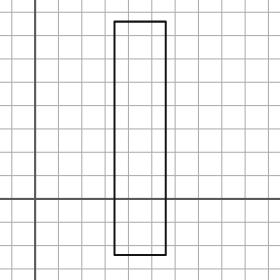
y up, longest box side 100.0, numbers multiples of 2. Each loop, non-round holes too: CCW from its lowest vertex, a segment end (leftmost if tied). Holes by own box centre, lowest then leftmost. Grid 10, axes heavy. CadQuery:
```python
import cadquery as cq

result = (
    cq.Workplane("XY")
    .moveTo(34.0, -24.0)
    .lineTo(56.0, -24.0)
    .lineTo(56.0, 76.0)
    .lineTo(34.0, 76.0)
    .close()
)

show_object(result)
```